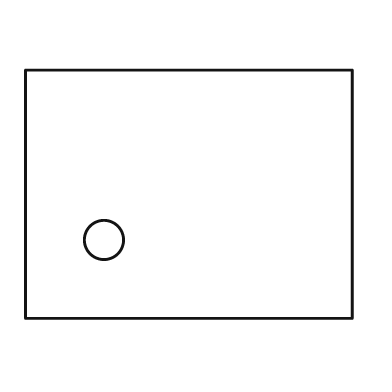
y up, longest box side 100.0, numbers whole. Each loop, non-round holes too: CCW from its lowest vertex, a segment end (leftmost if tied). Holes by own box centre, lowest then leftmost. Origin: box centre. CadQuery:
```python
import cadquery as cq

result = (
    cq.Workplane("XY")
    .moveTo(-50.0, -38.0)
    .lineTo(50.0, -38.0)
    .lineTo(50.0, 38.0)
    .lineTo(-50.0, 38.0)
    .close()
    .moveTo(-26.0, -14.0)
    .circle(6.0)
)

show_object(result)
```